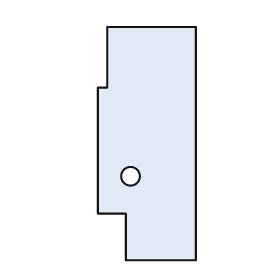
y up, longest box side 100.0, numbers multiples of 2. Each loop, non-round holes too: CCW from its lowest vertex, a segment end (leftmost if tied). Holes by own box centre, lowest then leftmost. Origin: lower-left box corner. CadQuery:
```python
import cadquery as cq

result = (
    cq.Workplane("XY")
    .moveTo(12.0, 0.0)
    .lineTo(42.0, 0.0)
    .lineTo(42.0, 100.0)
    .lineTo(4.0, 100.0)
    .lineTo(4.0, 74.0)
    .lineTo(0.0, 74.0)
    .lineTo(0.0, 20.0)
    .lineTo(12.0, 20.0)
    .close()
    .moveTo(14.0, 36.0)
    .circle(4.0)
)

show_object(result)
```